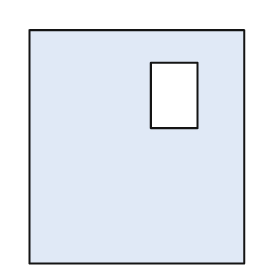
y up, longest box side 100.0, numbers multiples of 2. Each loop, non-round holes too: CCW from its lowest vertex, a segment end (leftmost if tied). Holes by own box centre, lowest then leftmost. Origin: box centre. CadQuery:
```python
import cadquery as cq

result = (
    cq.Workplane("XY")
    .moveTo(-46.0, -50.0)
    .lineTo(46.0, -50.0)
    .lineTo(46.0, 50.0)
    .lineTo(-46.0, 50.0)
    .close()
    .moveTo(6.0, 8.0)
    .lineTo(26.0, 8.0)
    .lineTo(26.0, 36.0)
    .lineTo(6.0, 36.0)
    .close()
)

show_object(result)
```